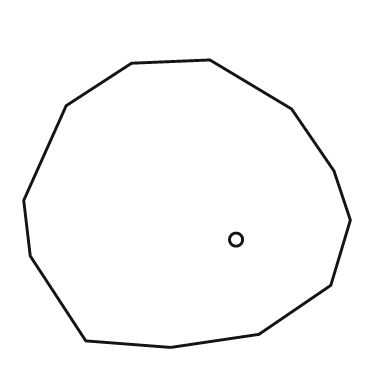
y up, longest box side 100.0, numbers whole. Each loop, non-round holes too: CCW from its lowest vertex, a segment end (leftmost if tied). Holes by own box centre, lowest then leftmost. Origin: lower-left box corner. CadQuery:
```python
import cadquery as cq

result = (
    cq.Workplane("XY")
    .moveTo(45.0, 0.0)
    .lineTo(72.0, 4.0)
    .lineTo(94.0, 19.0)
    .lineTo(100.0, 39.0)
    .lineTo(95.0, 54.0)
    .lineTo(82.0, 73.0)
    .lineTo(57.0, 88.0)
    .lineTo(33.0, 87.0)
    .lineTo(13.0, 74.0)
    .lineTo(0.0, 45.0)
    .lineTo(2.0, 28.0)
    .lineTo(19.0, 2.0)
    .close()
    .moveTo(65.0, 33.0)
    .circle(2.0)
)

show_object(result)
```